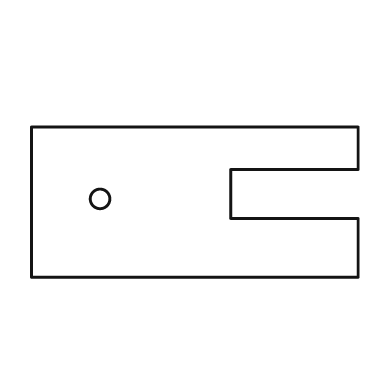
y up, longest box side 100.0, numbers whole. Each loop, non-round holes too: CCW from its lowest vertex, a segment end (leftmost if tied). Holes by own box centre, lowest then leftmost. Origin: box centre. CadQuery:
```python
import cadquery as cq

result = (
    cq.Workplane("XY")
    .moveTo(-50.0, -23.0)
    .lineTo(50.0, -23.0)
    .lineTo(50.0, -5.0)
    .lineTo(11.0, -5.0)
    .lineTo(11.0, 10.0)
    .lineTo(50.0, 10.0)
    .lineTo(50.0, 23.0)
    .lineTo(-50.0, 23.0)
    .close()
    .moveTo(-29.0, 1.0)
    .circle(3.0)
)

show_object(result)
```